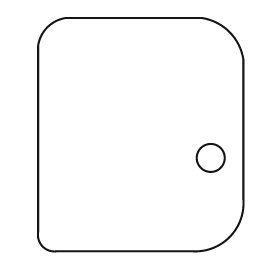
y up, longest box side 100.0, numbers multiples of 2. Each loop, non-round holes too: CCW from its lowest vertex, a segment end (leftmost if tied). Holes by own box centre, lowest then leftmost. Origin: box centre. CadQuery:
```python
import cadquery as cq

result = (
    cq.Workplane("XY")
    .moveTo(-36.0, -50.0)
    .lineTo(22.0, -50.0)
    .threePointArc((38.0, -44.0), (44.0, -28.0))
    .lineTo(44.0, 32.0)
    .threePointArc((38.0, 44.0), (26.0, 50.0))
    .lineTo(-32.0, 50.0)
    .threePointArc((-40.0, 46.0), (-44.0, 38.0))
    .lineTo(-44.0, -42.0)
    .threePointArc((-42.0, -48.0), (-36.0, -50.0))
    .close()
    .moveTo(30.0, -10.0)
    .circle(6.0)
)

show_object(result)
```